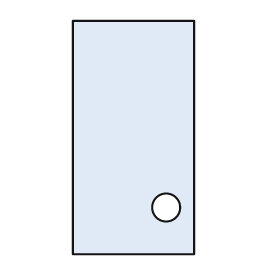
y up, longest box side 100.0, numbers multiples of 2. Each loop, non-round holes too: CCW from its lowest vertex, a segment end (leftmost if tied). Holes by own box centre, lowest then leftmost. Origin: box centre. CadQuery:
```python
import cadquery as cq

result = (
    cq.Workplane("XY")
    .moveTo(-26.0, -50.0)
    .lineTo(26.0, -50.0)
    .lineTo(26.0, 50.0)
    .lineTo(-26.0, 50.0)
    .close()
    .moveTo(14.0, -30.0)
    .circle(6.0)
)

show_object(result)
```